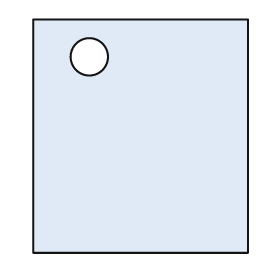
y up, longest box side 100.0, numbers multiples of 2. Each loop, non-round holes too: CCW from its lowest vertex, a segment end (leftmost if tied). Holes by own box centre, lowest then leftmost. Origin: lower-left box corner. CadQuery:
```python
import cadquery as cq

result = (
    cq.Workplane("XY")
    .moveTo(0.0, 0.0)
    .lineTo(92.0, 0.0)
    .lineTo(92.0, 100.0)
    .lineTo(0.0, 100.0)
    .close()
    .moveTo(24.0, 84.0)
    .circle(8.0)
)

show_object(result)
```